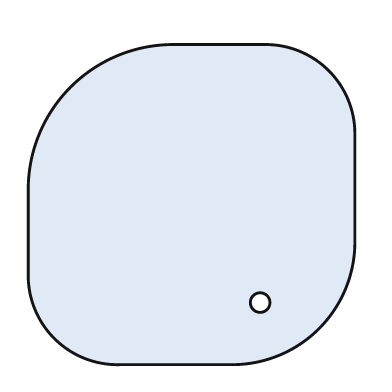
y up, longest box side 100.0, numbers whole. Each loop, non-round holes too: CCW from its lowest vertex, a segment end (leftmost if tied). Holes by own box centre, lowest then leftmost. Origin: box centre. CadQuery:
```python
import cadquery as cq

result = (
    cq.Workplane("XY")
    .moveTo(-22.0, -49.0)
    .lineTo(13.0, -49.0)
    .threePointArc((39.0, -38.0), (50.0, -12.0))
    .lineTo(50.0, 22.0)
    .threePointArc((42.0, 41.0), (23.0, 49.0))
    .lineTo(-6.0, 49.0)
    .threePointArc((-37.0, 36.0), (-50.0, 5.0))
    .lineTo(-50.0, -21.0)
    .threePointArc((-42.0, -41.0), (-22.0, -49.0))
    .close()
    .moveTo(21.0, -30.0)
    .circle(3.0)
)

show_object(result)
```